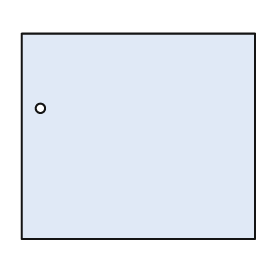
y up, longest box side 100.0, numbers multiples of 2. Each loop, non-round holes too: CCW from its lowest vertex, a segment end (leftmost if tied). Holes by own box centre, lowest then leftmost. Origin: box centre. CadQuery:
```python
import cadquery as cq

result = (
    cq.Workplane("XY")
    .moveTo(-50.0, -44.0)
    .lineTo(50.0, -44.0)
    .lineTo(50.0, 44.0)
    .lineTo(-50.0, 44.0)
    .close()
    .moveTo(-42.0, 12.0)
    .circle(2.0)
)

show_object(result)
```